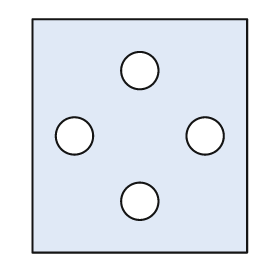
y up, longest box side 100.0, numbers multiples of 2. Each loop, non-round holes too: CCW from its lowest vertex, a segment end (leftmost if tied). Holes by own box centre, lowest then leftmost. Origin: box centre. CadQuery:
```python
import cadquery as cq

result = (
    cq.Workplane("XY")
    .moveTo(-46.0, -50.0)
    .lineTo(46.0, -50.0)
    .lineTo(46.0, 50.0)
    .lineTo(-46.0, 50.0)
    .close()
    .moveTo(0.0, -28.0)
    .circle(8.0)
    .moveTo(-28.0, 0.0)
    .circle(8.0)
    .moveTo(28.0, 0.0)
    .circle(8.0)
    .moveTo(0.0, 28.0)
    .circle(8.0)
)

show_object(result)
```